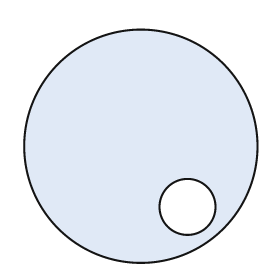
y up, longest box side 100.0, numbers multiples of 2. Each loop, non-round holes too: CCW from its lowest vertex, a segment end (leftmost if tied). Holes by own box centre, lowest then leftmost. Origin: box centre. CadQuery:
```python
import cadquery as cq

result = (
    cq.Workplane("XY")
    .moveTo(0.0, 0.0)
    .circle(50.0)
    .moveTo(20.0, -26.0)
    .circle(12.0)
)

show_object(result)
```